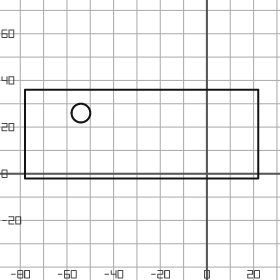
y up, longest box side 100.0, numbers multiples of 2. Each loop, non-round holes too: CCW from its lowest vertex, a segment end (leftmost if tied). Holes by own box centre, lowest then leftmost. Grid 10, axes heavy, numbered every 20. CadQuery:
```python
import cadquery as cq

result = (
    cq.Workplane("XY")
    .moveTo(-78.0, -2.0)
    .lineTo(22.0, -2.0)
    .lineTo(22.0, 36.0)
    .lineTo(-78.0, 36.0)
    .close()
    .moveTo(-54.0, 26.0)
    .circle(4.0)
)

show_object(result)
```